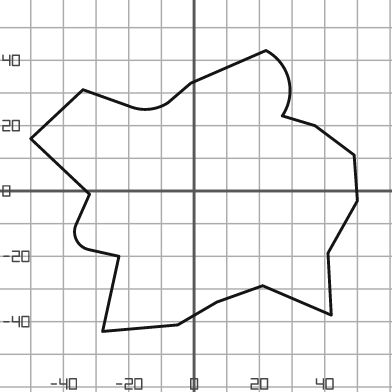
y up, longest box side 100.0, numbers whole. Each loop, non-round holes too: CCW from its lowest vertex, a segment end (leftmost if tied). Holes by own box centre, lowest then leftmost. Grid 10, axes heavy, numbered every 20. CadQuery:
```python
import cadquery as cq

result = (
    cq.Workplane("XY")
    .moveTo(-28.0, -43.0)
    .lineTo(-5.0, -41.0)
    .lineTo(7.0, -34.0)
    .lineTo(21.0, -29.0)
    .lineTo(42.0, -38.0)
    .lineTo(41.0, -19.0)
    .lineTo(50.0, -3.0)
    .lineTo(49.0, 11.0)
    .lineTo(37.0, 20.0)
    .lineTo(27.0, 23.0)
    .threePointArc((29.0, 34.0), (22.0, 43.0))
    .lineTo(-1.0, 33.0)
    .lineTo(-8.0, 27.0)
    .threePointArc((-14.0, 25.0), (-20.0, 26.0))
    .lineTo(-34.0, 31.0)
    .lineTo(-50.0, 16.0)
    .lineTo(-32.0, -1.0)
    .lineTo(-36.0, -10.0)
    .threePointArc((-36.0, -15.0), (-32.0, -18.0))
    .lineTo(-23.0, -20.0)
    .close()
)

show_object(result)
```